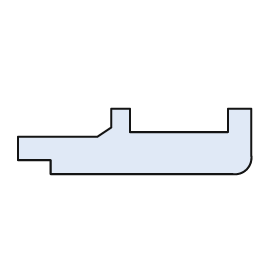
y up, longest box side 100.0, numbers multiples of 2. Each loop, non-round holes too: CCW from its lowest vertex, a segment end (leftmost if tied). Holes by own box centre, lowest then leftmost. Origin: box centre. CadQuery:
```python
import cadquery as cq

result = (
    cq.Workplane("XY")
    .moveTo(-36.0, -14.0)
    .lineTo(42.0, -14.0)
    .threePointArc((48.0, -12.0), (50.0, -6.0))
    .lineTo(50.0, 14.0)
    .lineTo(40.0, 14.0)
    .lineTo(40.0, 4.0)
    .lineTo(-2.0, 4.0)
    .lineTo(-2.0, 14.0)
    .lineTo(-10.0, 14.0)
    .lineTo(-10.0, 6.0)
    .lineTo(-16.0, 2.0)
    .lineTo(-50.0, 2.0)
    .lineTo(-50.0, -8.0)
    .lineTo(-36.0, -8.0)
    .close()
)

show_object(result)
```